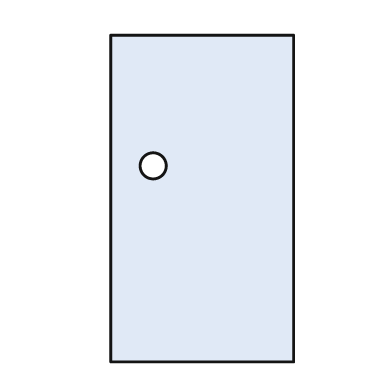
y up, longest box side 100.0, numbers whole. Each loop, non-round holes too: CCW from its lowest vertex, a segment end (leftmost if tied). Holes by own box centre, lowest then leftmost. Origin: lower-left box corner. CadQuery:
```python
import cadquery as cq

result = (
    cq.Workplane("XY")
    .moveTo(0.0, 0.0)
    .lineTo(56.0, 0.0)
    .lineTo(56.0, 100.0)
    .lineTo(0.0, 100.0)
    .close()
    .moveTo(13.0, 60.0)
    .circle(4.0)
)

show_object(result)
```